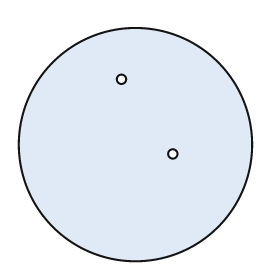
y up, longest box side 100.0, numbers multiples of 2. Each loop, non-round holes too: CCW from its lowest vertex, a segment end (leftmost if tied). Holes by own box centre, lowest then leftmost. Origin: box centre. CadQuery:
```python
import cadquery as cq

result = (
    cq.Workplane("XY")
    .moveTo(0.0, 0.0)
    .circle(50.0)
    .moveTo(16.0, -4.0)
    .circle(2.0)
    .moveTo(-6.0, 28.0)
    .circle(2.0)
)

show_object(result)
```